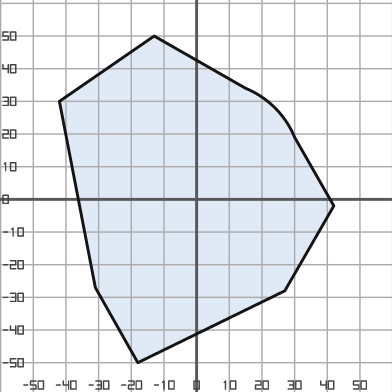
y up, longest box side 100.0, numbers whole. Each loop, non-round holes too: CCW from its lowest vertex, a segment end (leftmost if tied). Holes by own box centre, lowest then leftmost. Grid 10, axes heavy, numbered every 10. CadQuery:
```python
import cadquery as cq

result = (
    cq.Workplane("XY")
    .moveTo(-18.0, -50.0)
    .lineTo(27.0, -28.0)
    .lineTo(42.0, -2.0)
    .lineTo(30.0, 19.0)
    .threePointArc((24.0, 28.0), (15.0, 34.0))
    .lineTo(-13.0, 50.0)
    .lineTo(-42.0, 30.0)
    .lineTo(-31.0, -27.0)
    .close()
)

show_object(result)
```